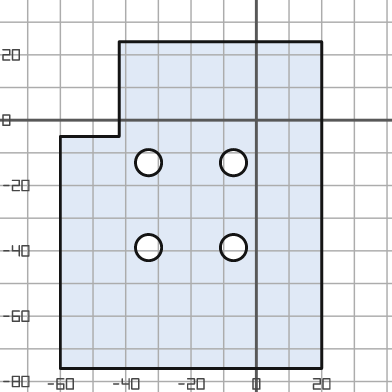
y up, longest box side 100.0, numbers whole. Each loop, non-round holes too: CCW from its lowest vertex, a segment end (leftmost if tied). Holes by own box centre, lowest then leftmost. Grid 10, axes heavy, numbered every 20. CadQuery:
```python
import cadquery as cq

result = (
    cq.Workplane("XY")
    .moveTo(-60.0, -76.0)
    .lineTo(20.0, -76.0)
    .lineTo(20.0, 24.0)
    .lineTo(-42.0, 24.0)
    .lineTo(-42.0, -5.0)
    .lineTo(-60.0, -5.0)
    .close()
    .moveTo(-33.0, -39.0)
    .circle(4.0)
    .moveTo(-7.0, -39.0)
    .circle(4.0)
    .moveTo(-33.0, -13.0)
    .circle(4.0)
    .moveTo(-7.0, -13.0)
    .circle(4.0)
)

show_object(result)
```